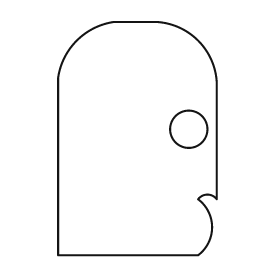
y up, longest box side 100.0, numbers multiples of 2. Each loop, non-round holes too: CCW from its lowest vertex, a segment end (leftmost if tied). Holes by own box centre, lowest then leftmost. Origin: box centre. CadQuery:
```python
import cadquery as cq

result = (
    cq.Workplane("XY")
    .moveTo(-34.0, -50.0)
    .lineTo(26.0, -50.0)
    .threePointArc((32.0, -38.0), (26.0, -26.0))
    .threePointArc((30.0, -24.0), (34.0, -26.0))
    .lineTo(34.0, 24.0)
    .threePointArc((26.0, 42.0), (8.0, 50.0))
    .lineTo(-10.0, 50.0)
    .threePointArc((-26.0, 42.0), (-34.0, 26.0))
    .close()
    .moveTo(22.0, 4.0)
    .circle(8.0)
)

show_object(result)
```